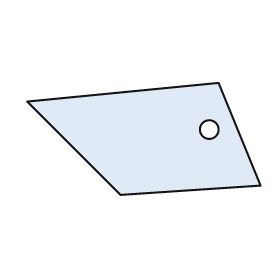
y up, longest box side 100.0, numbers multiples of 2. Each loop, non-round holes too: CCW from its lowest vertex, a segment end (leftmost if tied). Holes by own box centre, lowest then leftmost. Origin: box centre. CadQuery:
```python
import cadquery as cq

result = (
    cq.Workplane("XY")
    .moveTo(-10.0, -24.0)
    .lineTo(50.0, -20.0)
    .lineTo(32.0, 24.0)
    .lineTo(-50.0, 16.0)
    .close()
    .moveTo(28.0, 4.0)
    .circle(4.0)
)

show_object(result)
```